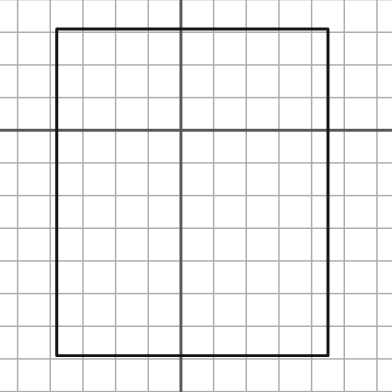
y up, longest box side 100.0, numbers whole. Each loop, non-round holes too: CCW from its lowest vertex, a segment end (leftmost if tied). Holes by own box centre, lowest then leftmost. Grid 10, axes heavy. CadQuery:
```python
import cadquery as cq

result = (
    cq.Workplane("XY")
    .moveTo(-38.0, -69.0)
    .lineTo(45.0, -69.0)
    .lineTo(45.0, 31.0)
    .lineTo(-38.0, 31.0)
    .close()
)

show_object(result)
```